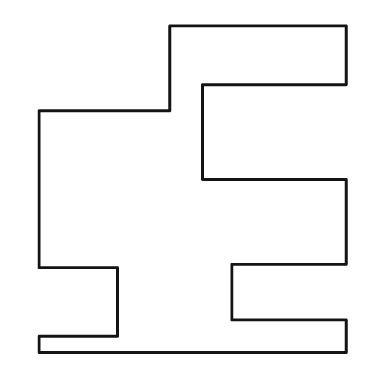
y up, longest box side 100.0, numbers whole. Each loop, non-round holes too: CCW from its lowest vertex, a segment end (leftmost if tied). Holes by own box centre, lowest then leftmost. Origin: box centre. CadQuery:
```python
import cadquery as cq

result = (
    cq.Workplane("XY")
    .moveTo(-47.0, -50.0)
    .lineTo(47.0, -50.0)
    .lineTo(47.0, -40.0)
    .lineTo(12.0, -40.0)
    .lineTo(12.0, -23.0)
    .lineTo(47.0, -23.0)
    .lineTo(47.0, 3.0)
    .lineTo(3.0, 3.0)
    .lineTo(3.0, 32.0)
    .lineTo(47.0, 32.0)
    .lineTo(47.0, 50.0)
    .lineTo(-7.0, 50.0)
    .lineTo(-7.0, 24.0)
    .lineTo(-47.0, 24.0)
    .lineTo(-47.0, -24.0)
    .lineTo(-23.0, -24.0)
    .lineTo(-23.0, -45.0)
    .lineTo(-47.0, -45.0)
    .close()
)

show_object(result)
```